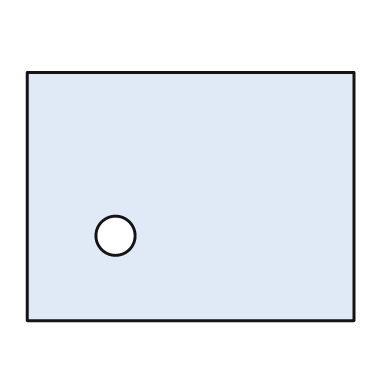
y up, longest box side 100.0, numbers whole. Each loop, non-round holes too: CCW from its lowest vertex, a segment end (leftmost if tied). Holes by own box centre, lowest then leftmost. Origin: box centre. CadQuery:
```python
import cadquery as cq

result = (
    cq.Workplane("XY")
    .moveTo(-50.0, -38.0)
    .lineTo(50.0, -38.0)
    .lineTo(50.0, 38.0)
    .lineTo(-50.0, 38.0)
    .close()
    .moveTo(-23.0, -12.0)
    .circle(6.0)
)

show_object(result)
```